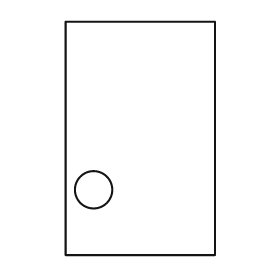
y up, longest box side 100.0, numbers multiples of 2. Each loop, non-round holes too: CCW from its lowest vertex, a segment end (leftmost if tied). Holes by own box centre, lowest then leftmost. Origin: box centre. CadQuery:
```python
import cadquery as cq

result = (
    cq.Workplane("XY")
    .moveTo(-32.0, -50.0)
    .lineTo(32.0, -50.0)
    .lineTo(32.0, 50.0)
    .lineTo(-32.0, 50.0)
    .close()
    .moveTo(-20.0, -22.0)
    .circle(8.0)
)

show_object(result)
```